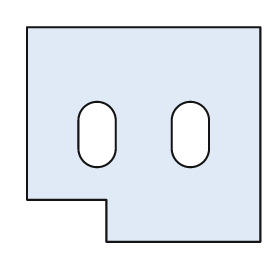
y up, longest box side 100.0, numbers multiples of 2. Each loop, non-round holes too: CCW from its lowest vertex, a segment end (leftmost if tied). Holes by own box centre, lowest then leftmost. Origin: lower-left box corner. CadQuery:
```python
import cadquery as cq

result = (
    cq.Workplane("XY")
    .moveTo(34.0, 0.0)
    .lineTo(100.0, 0.0)
    .lineTo(100.0, 92.0)
    .lineTo(0.0, 92.0)
    .lineTo(0.0, 18.0)
    .lineTo(34.0, 18.0)
    .close()
    .moveTo(22.0, 40.0)
    .threePointArc((30.0, 32.0), (38.0, 40.0))
    .lineTo(38.0, 52.0)
    .threePointArc((30.0, 60.0), (22.0, 52.0))
    .close()
    .moveTo(62.0, 40.0)
    .threePointArc((70.0, 32.0), (78.0, 40.0))
    .lineTo(78.0, 52.0)
    .threePointArc((70.0, 60.0), (62.0, 52.0))
    .close()
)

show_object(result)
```